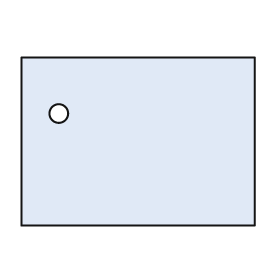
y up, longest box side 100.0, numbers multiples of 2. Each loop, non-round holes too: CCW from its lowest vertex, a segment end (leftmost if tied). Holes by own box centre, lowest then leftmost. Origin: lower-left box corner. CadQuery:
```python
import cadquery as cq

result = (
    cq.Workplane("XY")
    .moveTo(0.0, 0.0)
    .lineTo(100.0, 0.0)
    .lineTo(100.0, 72.0)
    .lineTo(0.0, 72.0)
    .close()
    .moveTo(16.0, 48.0)
    .circle(4.0)
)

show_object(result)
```